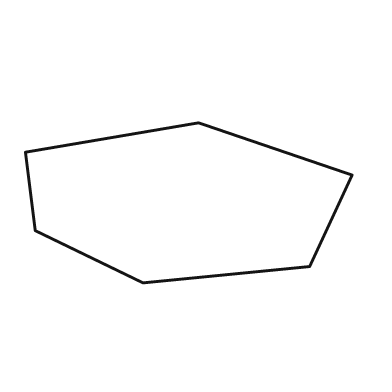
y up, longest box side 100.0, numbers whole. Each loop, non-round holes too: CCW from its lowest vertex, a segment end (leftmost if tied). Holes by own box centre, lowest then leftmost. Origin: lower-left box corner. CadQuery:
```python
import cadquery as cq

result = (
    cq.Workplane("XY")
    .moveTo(36.0, 0.0)
    .lineTo(87.0, 5.0)
    .lineTo(100.0, 33.0)
    .lineTo(53.0, 49.0)
    .lineTo(0.0, 40.0)
    .lineTo(3.0, 16.0)
    .close()
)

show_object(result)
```